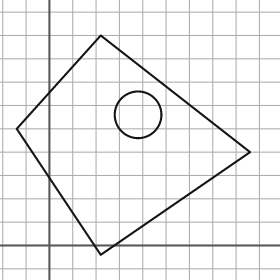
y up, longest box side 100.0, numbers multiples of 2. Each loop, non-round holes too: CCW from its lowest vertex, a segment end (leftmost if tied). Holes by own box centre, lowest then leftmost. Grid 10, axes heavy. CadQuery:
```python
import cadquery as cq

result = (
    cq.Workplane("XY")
    .moveTo(22.0, -4.0)
    .lineTo(86.0, 40.0)
    .lineTo(22.0, 90.0)
    .lineTo(-14.0, 50.0)
    .close()
    .moveTo(38.0, 56.0)
    .circle(10.0)
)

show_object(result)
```